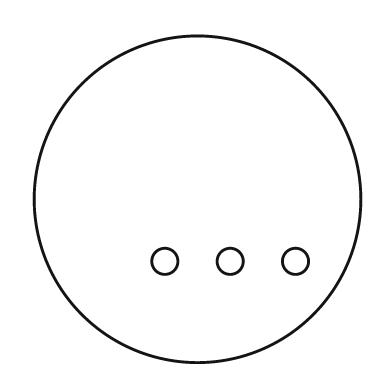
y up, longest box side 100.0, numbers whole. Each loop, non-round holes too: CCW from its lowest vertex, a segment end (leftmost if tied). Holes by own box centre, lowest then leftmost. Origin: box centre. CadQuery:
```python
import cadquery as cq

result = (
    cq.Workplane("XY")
    .moveTo(0.0, 0.0)
    .circle(50.0)
    .moveTo(-10.0, -19.0)
    .circle(4.0)
    .moveTo(10.0, -19.0)
    .circle(4.0)
    .moveTo(30.0, -19.0)
    .circle(4.0)
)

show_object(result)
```